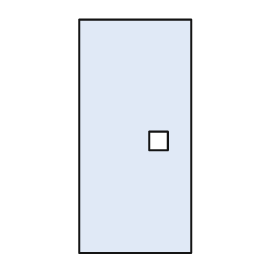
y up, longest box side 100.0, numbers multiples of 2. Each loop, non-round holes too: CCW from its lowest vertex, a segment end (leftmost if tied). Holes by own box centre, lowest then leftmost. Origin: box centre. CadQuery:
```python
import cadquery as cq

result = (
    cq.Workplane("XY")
    .moveTo(-24.0, -50.0)
    .lineTo(24.0, -50.0)
    .lineTo(24.0, 50.0)
    .lineTo(-24.0, 50.0)
    .close()
    .moveTo(6.0, -6.0)
    .lineTo(14.0, -6.0)
    .lineTo(14.0, 2.0)
    .lineTo(6.0, 2.0)
    .close()
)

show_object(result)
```